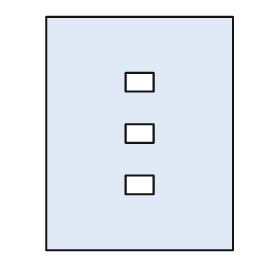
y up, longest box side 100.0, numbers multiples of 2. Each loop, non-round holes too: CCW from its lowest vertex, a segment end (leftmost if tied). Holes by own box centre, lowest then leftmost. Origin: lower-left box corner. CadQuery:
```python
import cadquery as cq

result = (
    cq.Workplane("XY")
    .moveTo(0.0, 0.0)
    .lineTo(80.0, 0.0)
    .lineTo(80.0, 100.0)
    .lineTo(0.0, 100.0)
    .close()
    .moveTo(34.0, 24.0)
    .lineTo(46.0, 24.0)
    .lineTo(46.0, 32.0)
    .lineTo(34.0, 32.0)
    .close()
    .moveTo(34.0, 46.0)
    .lineTo(46.0, 46.0)
    .lineTo(46.0, 54.0)
    .lineTo(34.0, 54.0)
    .close()
    .moveTo(34.0, 68.0)
    .lineTo(46.0, 68.0)
    .lineTo(46.0, 76.0)
    .lineTo(34.0, 76.0)
    .close()
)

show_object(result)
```